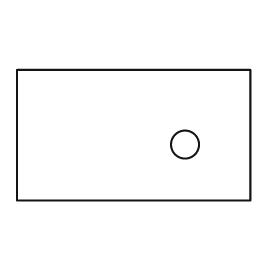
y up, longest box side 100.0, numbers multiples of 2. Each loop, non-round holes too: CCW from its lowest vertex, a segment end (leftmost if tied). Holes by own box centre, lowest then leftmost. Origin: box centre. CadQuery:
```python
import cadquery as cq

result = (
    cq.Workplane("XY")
    .moveTo(-50.0, -28.0)
    .lineTo(50.0, -28.0)
    .lineTo(50.0, 28.0)
    .lineTo(-50.0, 28.0)
    .close()
    .moveTo(22.0, -4.0)
    .circle(6.0)
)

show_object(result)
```